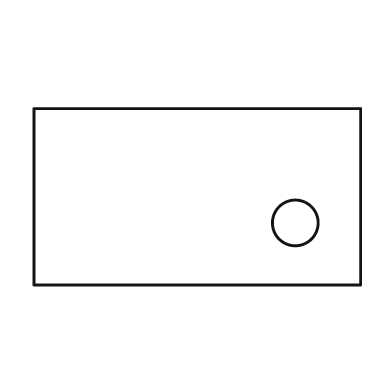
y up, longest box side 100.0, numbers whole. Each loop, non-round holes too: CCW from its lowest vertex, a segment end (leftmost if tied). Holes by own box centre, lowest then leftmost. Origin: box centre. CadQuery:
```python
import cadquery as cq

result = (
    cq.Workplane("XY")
    .moveTo(-50.0, -27.0)
    .lineTo(50.0, -27.0)
    .lineTo(50.0, 27.0)
    .lineTo(-50.0, 27.0)
    .close()
    .moveTo(30.0, -8.0)
    .circle(7.0)
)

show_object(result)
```